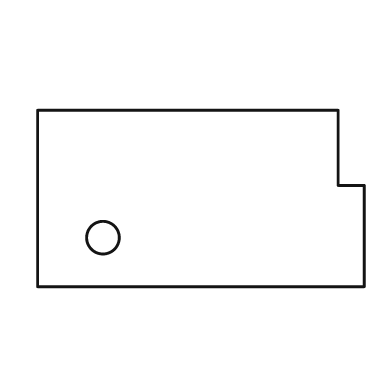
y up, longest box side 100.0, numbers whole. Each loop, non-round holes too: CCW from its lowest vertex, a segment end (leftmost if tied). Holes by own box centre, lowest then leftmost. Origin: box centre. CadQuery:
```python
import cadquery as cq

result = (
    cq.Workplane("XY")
    .moveTo(-50.0, -27.0)
    .lineTo(50.0, -27.0)
    .lineTo(50.0, 4.0)
    .lineTo(42.0, 4.0)
    .lineTo(42.0, 27.0)
    .lineTo(-50.0, 27.0)
    .close()
    .moveTo(-30.0, -12.0)
    .circle(5.0)
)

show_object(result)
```